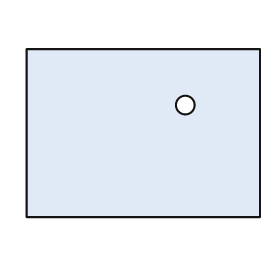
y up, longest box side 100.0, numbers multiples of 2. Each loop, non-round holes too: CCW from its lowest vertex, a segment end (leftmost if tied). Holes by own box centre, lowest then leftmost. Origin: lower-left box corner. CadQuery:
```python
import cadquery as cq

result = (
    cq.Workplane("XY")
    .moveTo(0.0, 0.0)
    .lineTo(100.0, 0.0)
    .lineTo(100.0, 72.0)
    .lineTo(0.0, 72.0)
    .close()
    .moveTo(68.0, 48.0)
    .circle(4.0)
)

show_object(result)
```